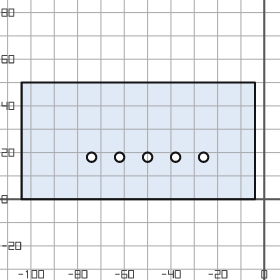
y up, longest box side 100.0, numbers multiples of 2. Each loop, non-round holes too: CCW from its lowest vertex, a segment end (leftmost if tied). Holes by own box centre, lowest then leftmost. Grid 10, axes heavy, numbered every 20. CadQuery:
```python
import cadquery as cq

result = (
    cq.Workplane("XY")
    .moveTo(-104.0, 0.0)
    .lineTo(-4.0, 0.0)
    .lineTo(-4.0, 50.0)
    .lineTo(-104.0, 50.0)
    .close()
    .moveTo(-74.0, 18.0)
    .circle(2.0)
    .moveTo(-62.0, 18.0)
    .circle(2.0)
    .moveTo(-50.0, 18.0)
    .circle(2.0)
    .moveTo(-38.0, 18.0)
    .circle(2.0)
    .moveTo(-26.0, 18.0)
    .circle(2.0)
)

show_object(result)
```